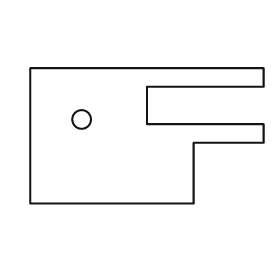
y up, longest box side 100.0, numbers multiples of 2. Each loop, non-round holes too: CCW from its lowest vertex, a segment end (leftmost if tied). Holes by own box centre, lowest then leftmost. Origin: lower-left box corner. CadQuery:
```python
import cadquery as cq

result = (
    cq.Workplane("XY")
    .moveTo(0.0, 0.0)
    .lineTo(70.0, 0.0)
    .lineTo(70.0, 26.0)
    .lineTo(100.0, 26.0)
    .lineTo(100.0, 34.0)
    .lineTo(50.0, 34.0)
    .lineTo(50.0, 50.0)
    .lineTo(100.0, 50.0)
    .lineTo(100.0, 58.0)
    .lineTo(0.0, 58.0)
    .close()
    .moveTo(22.0, 36.0)
    .circle(4.0)
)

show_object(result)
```